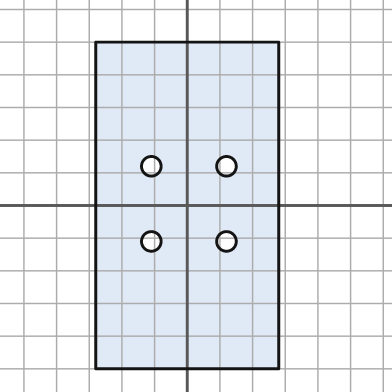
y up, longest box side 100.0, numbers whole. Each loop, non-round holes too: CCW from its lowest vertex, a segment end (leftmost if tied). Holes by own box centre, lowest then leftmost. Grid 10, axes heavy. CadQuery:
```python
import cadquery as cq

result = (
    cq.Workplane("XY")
    .moveTo(-28.0, -50.0)
    .lineTo(28.0, -50.0)
    .lineTo(28.0, 50.0)
    .lineTo(-28.0, 50.0)
    .close()
    .moveTo(-11.0, -11.0)
    .circle(3.0)
    .moveTo(12.0, -11.0)
    .circle(3.0)
    .moveTo(-11.0, 12.0)
    .circle(3.0)
    .moveTo(12.0, 12.0)
    .circle(3.0)
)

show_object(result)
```